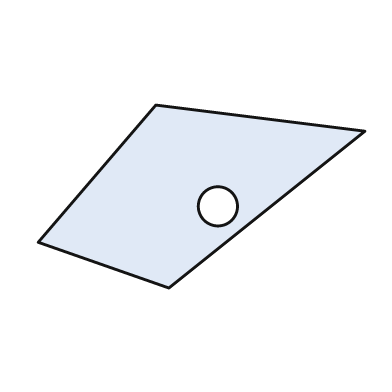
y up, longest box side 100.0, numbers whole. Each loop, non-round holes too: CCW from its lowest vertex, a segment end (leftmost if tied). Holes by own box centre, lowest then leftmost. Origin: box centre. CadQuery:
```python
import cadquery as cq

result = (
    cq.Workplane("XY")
    .moveTo(-10.0, -28.0)
    .lineTo(50.0, 20.0)
    .lineTo(-14.0, 28.0)
    .lineTo(-50.0, -14.0)
    .close()
    .moveTo(5.0, -3.0)
    .circle(6.0)
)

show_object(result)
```